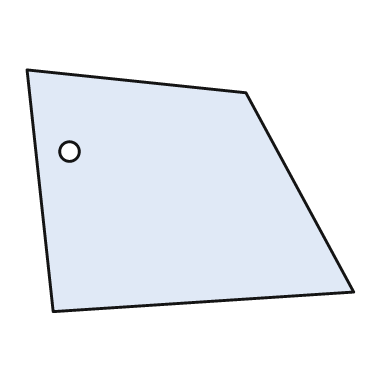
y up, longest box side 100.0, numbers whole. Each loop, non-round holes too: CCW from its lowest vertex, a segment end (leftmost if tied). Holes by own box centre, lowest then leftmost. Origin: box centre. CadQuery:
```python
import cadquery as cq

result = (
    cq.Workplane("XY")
    .moveTo(-42.0, -37.0)
    .lineTo(50.0, -31.0)
    .lineTo(17.0, 30.0)
    .lineTo(-50.0, 37.0)
    .close()
    .moveTo(-37.0, 12.0)
    .circle(3.0)
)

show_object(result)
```